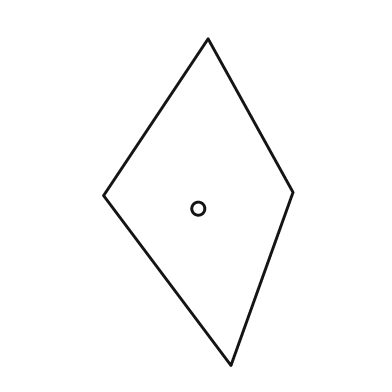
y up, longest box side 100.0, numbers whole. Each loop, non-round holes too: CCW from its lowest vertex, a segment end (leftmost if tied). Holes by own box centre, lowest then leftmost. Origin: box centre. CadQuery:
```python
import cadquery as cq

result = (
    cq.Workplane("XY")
    .moveTo(10.0, -50.0)
    .lineTo(29.0, 3.0)
    .lineTo(3.0, 50.0)
    .lineTo(-29.0, 2.0)
    .close()
    .moveTo(0.0, -2.0)
    .circle(2.0)
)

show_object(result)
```